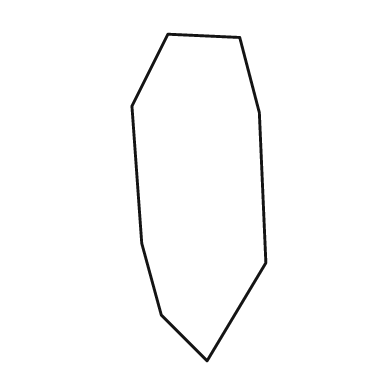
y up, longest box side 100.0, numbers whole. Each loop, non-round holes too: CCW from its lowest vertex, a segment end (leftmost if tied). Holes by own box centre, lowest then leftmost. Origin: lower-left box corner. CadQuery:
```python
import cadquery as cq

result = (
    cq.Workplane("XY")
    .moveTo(23.0, 0.0)
    .lineTo(41.0, 30.0)
    .lineTo(39.0, 76.0)
    .lineTo(33.0, 99.0)
    .lineTo(11.0, 100.0)
    .lineTo(0.0, 78.0)
    .lineTo(3.0, 36.0)
    .lineTo(9.0, 14.0)
    .close()
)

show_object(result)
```